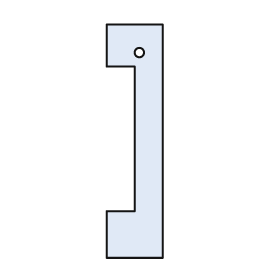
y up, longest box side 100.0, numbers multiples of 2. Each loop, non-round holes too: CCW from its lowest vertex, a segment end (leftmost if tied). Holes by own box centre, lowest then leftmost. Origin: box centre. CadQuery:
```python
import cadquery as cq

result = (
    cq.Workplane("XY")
    .moveTo(-12.0, -50.0)
    .lineTo(12.0, -50.0)
    .lineTo(12.0, 50.0)
    .lineTo(-12.0, 50.0)
    .lineTo(-12.0, 32.0)
    .lineTo(0.0, 32.0)
    .lineTo(0.0, -30.0)
    .lineTo(-12.0, -30.0)
    .close()
    .moveTo(2.0, 38.0)
    .circle(2.0)
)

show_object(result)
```